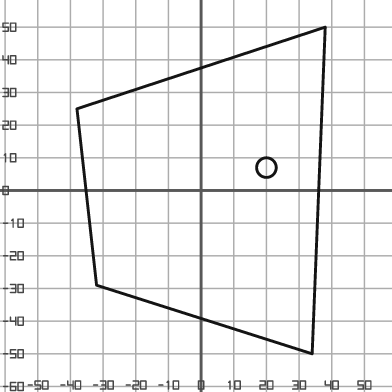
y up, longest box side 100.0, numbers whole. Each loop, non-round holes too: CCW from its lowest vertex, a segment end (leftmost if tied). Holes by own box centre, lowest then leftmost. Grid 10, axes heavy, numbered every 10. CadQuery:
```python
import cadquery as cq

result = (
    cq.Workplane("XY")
    .moveTo(34.0, -50.0)
    .lineTo(38.0, 50.0)
    .lineTo(-38.0, 25.0)
    .lineTo(-32.0, -29.0)
    .close()
    .moveTo(20.0, 7.0)
    .circle(3.0)
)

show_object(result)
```